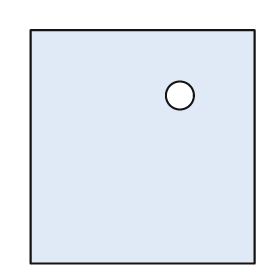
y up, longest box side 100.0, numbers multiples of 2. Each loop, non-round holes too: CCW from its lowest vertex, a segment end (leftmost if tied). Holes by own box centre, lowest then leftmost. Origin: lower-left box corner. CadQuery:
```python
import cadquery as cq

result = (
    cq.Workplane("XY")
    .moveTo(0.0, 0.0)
    .lineTo(96.0, 0.0)
    .lineTo(96.0, 100.0)
    .lineTo(0.0, 100.0)
    .close()
    .moveTo(64.0, 72.0)
    .circle(6.0)
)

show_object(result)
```